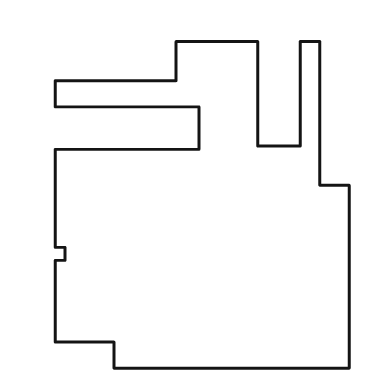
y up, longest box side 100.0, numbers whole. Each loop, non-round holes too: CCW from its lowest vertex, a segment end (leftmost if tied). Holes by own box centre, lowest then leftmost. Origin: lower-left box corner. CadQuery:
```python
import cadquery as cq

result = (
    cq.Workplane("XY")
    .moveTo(18.0, 0.0)
    .lineTo(90.0, 0.0)
    .lineTo(90.0, 56.0)
    .lineTo(81.0, 56.0)
    .lineTo(81.0, 100.0)
    .lineTo(75.0, 100.0)
    .lineTo(75.0, 68.0)
    .lineTo(62.0, 68.0)
    .lineTo(62.0, 100.0)
    .lineTo(37.0, 100.0)
    .lineTo(37.0, 88.0)
    .lineTo(0.0, 88.0)
    .lineTo(0.0, 80.0)
    .lineTo(44.0, 80.0)
    .lineTo(44.0, 67.0)
    .lineTo(0.0, 67.0)
    .lineTo(0.0, 37.0)
    .lineTo(3.0, 37.0)
    .lineTo(3.0, 33.0)
    .lineTo(0.0, 33.0)
    .lineTo(0.0, 8.0)
    .lineTo(18.0, 8.0)
    .close()
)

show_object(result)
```